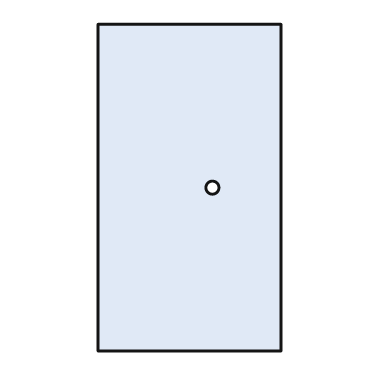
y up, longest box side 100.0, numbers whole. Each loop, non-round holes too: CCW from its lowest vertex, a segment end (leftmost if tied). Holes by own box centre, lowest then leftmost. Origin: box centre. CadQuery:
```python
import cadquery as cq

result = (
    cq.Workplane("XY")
    .moveTo(-28.0, -50.0)
    .lineTo(28.0, -50.0)
    .lineTo(28.0, 50.0)
    .lineTo(-28.0, 50.0)
    .close()
    .moveTo(7.0, 0.0)
    .circle(2.0)
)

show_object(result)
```